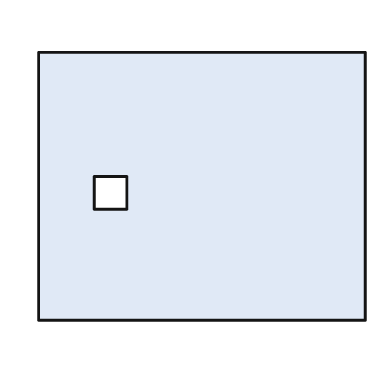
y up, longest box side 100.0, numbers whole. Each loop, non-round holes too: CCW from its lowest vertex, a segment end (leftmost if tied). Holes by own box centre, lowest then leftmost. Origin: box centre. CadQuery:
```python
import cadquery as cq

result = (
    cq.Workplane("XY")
    .moveTo(-50.0, -41.0)
    .lineTo(50.0, -41.0)
    .lineTo(50.0, 41.0)
    .lineTo(-50.0, 41.0)
    .close()
    .moveTo(-33.0, -7.0)
    .lineTo(-23.0, -7.0)
    .lineTo(-23.0, 3.0)
    .lineTo(-33.0, 3.0)
    .close()
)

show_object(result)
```